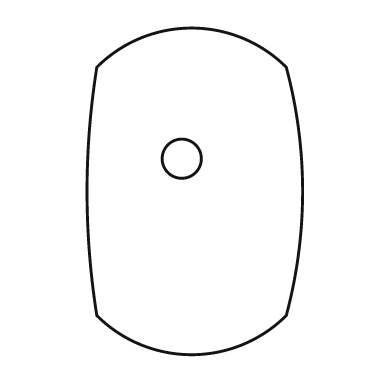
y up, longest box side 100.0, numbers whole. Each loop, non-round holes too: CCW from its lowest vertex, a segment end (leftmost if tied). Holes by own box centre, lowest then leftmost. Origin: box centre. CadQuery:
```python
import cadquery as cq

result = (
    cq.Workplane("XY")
    .moveTo(-30.0, -38.0)
    .threePointArc((-1.0, -50.0), (28.0, -38.0))
    .threePointArc((33.0, 0.0), (28.0, 38.0))
    .threePointArc((-1.0, 50.0), (-30.0, 38.0))
    .threePointArc((-33.0, 0.0), (-30.0, -38.0))
    .close()
    .moveTo(-4.0, 10.0)
    .circle(6.0)
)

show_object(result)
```